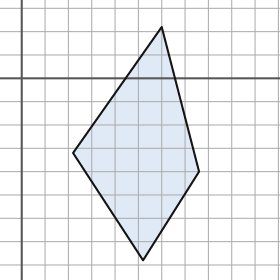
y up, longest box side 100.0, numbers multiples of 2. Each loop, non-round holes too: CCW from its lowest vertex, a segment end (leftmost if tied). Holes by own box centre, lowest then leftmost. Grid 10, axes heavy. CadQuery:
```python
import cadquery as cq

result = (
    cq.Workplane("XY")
    .moveTo(52.0, -78.0)
    .lineTo(76.0, -40.0)
    .lineTo(60.0, 22.0)
    .lineTo(22.0, -32.0)
    .close()
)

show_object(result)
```